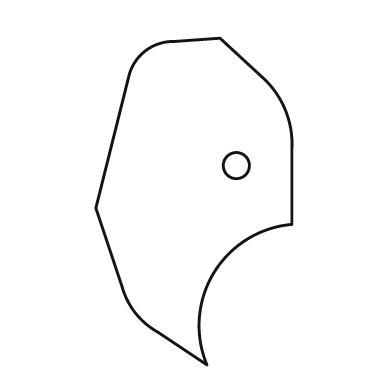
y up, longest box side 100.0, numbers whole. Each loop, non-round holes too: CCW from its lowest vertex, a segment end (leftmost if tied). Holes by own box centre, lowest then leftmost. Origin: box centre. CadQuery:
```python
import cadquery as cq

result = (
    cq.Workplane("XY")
    .moveTo(4.0, -50.0)
    .threePointArc((6.0, -22.0), (30.0, -7.0))
    .lineTo(30.0, 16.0)
    .threePointArc((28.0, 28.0), (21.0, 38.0))
    .lineTo(8.0, 50.0)
    .lineTo(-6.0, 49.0)
    .threePointArc((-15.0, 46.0), (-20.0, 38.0))
    .lineTo(-30.0, -2.0)
    .lineTo(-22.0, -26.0)
    .threePointArc((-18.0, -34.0), (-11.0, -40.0))
    .close()
    .moveTo(13.0, 11.0)
    .circle(4.0)
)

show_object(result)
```